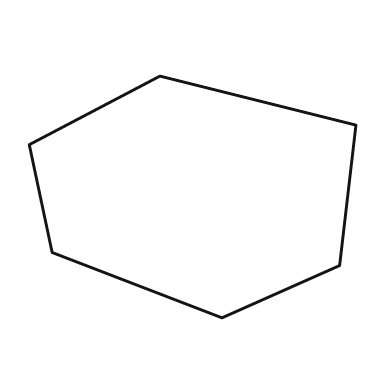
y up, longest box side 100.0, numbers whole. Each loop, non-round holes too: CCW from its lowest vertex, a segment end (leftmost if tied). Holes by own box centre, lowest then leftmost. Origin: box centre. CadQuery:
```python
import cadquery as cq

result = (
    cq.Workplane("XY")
    .moveTo(9.0, -37.0)
    .lineTo(45.0, -21.0)
    .lineTo(50.0, 22.0)
    .lineTo(-10.0, 37.0)
    .lineTo(-50.0, 16.0)
    .lineTo(-43.0, -17.0)
    .close()
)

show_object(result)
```